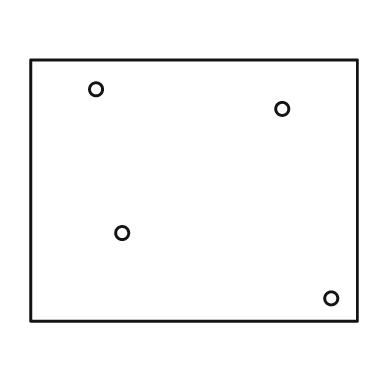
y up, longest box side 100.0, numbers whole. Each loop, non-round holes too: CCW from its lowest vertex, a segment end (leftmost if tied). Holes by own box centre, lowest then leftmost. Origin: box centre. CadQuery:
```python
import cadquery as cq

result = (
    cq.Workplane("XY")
    .moveTo(-50.0, -40.0)
    .lineTo(50.0, -40.0)
    .lineTo(50.0, 40.0)
    .lineTo(-50.0, 40.0)
    .close()
    .moveTo(42.0, -33.0)
    .circle(2.0)
    .moveTo(-22.0, -13.0)
    .circle(2.0)
    .moveTo(27.0, 25.0)
    .circle(2.0)
    .moveTo(-30.0, 31.0)
    .circle(2.0)
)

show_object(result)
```